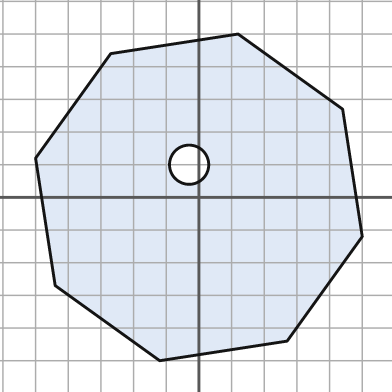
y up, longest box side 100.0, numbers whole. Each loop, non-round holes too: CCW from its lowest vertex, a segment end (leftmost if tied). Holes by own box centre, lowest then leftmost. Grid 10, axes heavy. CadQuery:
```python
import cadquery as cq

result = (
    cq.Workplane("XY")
    .moveTo(-12.0, -50.0)
    .lineTo(27.0, -44.0)
    .lineTo(50.0, -12.0)
    .lineTo(44.0, 27.0)
    .lineTo(12.0, 50.0)
    .lineTo(-27.0, 44.0)
    .lineTo(-50.0, 12.0)
    .lineTo(-44.0, -27.0)
    .close()
    .moveTo(-3.0, 10.0)
    .circle(6.0)
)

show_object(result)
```